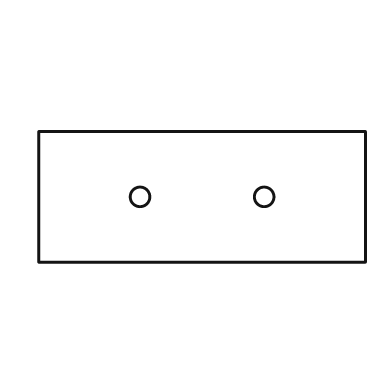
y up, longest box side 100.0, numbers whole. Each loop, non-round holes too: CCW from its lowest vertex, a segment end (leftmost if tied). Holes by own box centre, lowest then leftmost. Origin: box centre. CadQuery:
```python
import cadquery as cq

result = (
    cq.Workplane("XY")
    .moveTo(-50.0, -20.0)
    .lineTo(50.0, -20.0)
    .lineTo(50.0, 20.0)
    .lineTo(-50.0, 20.0)
    .close()
    .moveTo(-19.0, 0.0)
    .circle(3.0)
    .moveTo(19.0, 0.0)
    .circle(3.0)
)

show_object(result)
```